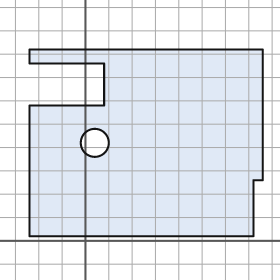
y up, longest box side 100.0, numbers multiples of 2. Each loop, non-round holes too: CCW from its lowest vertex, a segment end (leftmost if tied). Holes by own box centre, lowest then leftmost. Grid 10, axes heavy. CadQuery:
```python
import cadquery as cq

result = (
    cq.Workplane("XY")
    .moveTo(-24.0, 2.0)
    .lineTo(72.0, 2.0)
    .lineTo(72.0, 26.0)
    .lineTo(76.0, 26.0)
    .lineTo(76.0, 82.0)
    .lineTo(-24.0, 82.0)
    .lineTo(-24.0, 76.0)
    .lineTo(8.0, 76.0)
    .lineTo(8.0, 58.0)
    .lineTo(-24.0, 58.0)
    .close()
    .moveTo(4.0, 42.0)
    .circle(6.0)
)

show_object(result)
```